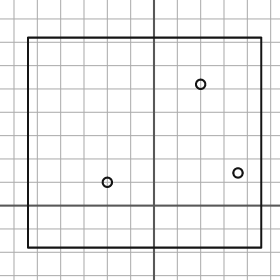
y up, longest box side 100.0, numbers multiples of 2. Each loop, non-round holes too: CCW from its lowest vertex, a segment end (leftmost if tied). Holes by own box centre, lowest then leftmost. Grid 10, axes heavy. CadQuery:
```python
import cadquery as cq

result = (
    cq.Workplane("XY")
    .moveTo(-54.0, -18.0)
    .lineTo(46.0, -18.0)
    .lineTo(46.0, 72.0)
    .lineTo(-54.0, 72.0)
    .close()
    .moveTo(-20.0, 10.0)
    .circle(2.0)
    .moveTo(36.0, 14.0)
    .circle(2.0)
    .moveTo(20.0, 52.0)
    .circle(2.0)
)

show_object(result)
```